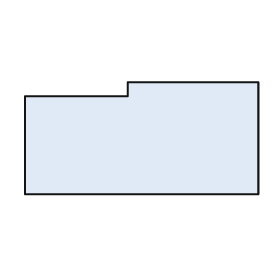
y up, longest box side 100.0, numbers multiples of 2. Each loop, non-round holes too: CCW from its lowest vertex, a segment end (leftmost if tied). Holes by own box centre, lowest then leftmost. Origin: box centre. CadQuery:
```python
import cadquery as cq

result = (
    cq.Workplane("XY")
    .moveTo(-50.0, -24.0)
    .lineTo(50.0, -24.0)
    .lineTo(50.0, 24.0)
    .lineTo(-6.0, 24.0)
    .lineTo(-6.0, 18.0)
    .lineTo(-50.0, 18.0)
    .close()
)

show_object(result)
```